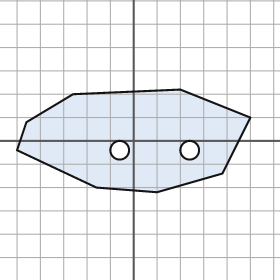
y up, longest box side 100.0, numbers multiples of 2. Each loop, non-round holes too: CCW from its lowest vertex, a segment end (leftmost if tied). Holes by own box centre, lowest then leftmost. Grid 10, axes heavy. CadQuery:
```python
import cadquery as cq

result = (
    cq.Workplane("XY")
    .moveTo(10.0, -22.0)
    .lineTo(38.0, -14.0)
    .lineTo(50.0, 10.0)
    .lineTo(20.0, 22.0)
    .lineTo(-26.0, 20.0)
    .lineTo(-46.0, 8.0)
    .lineTo(-50.0, -4.0)
    .lineTo(-16.0, -20.0)
    .close()
    .moveTo(-6.0, -4.0)
    .circle(4.0)
    .moveTo(24.0, -4.0)
    .circle(4.0)
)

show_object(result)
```